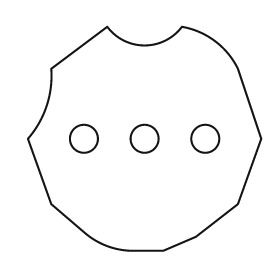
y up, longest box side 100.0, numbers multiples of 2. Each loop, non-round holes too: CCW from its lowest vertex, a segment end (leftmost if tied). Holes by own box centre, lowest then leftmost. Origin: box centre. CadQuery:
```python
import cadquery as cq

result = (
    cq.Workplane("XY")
    .moveTo(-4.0, -48.0)
    .lineTo(8.0, -48.0)
    .lineTo(22.0, -42.0)
    .lineTo(40.0, -28.0)
    .lineTo(50.0, 0.0)
    .lineTo(40.0, 30.0)
    .threePointArc((30.0, 42.0), (16.0, 48.0))
    .threePointArc((0.0, 40.0), (-16.0, 48.0))
    .lineTo(-40.0, 30.0)
    .threePointArc((-42.0, 14.0), (-50.0, 0.0))
    .lineTo(-40.0, -28.0)
    .lineTo(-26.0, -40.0)
    .threePointArc((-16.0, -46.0), (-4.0, -48.0))
    .close()
    .moveTo(-26.0, 0.0)
    .circle(6.0)
    .moveTo(0.0, 0.0)
    .circle(6.0)
    .moveTo(26.0, 0.0)
    .circle(6.0)
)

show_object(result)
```